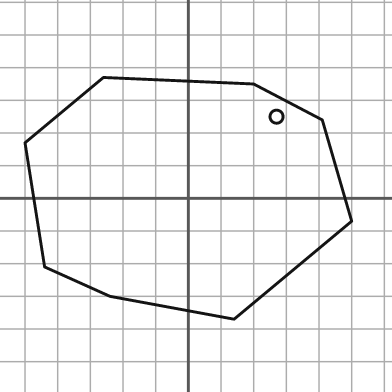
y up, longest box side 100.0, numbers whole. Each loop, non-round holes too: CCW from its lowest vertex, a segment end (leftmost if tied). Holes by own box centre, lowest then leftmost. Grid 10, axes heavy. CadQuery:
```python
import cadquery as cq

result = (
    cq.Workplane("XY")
    .moveTo(14.0, -37.0)
    .lineTo(50.0, -7.0)
    .lineTo(41.0, 24.0)
    .lineTo(20.0, 35.0)
    .lineTo(-26.0, 37.0)
    .lineTo(-50.0, 17.0)
    .lineTo(-44.0, -21.0)
    .lineTo(-24.0, -30.0)
    .close()
    .moveTo(27.0, 25.0)
    .circle(2.0)
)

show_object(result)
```